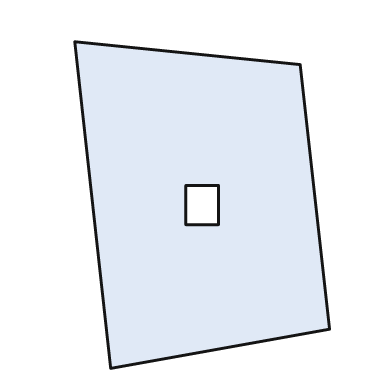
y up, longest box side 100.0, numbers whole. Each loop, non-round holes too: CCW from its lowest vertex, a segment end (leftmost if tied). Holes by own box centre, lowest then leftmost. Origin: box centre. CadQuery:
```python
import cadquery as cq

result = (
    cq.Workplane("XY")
    .moveTo(-28.0, -50.0)
    .lineTo(39.0, -38.0)
    .lineTo(30.0, 43.0)
    .lineTo(-39.0, 50.0)
    .close()
    .moveTo(-5.0, -6.0)
    .lineTo(5.0, -6.0)
    .lineTo(5.0, 6.0)
    .lineTo(-5.0, 6.0)
    .close()
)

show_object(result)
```